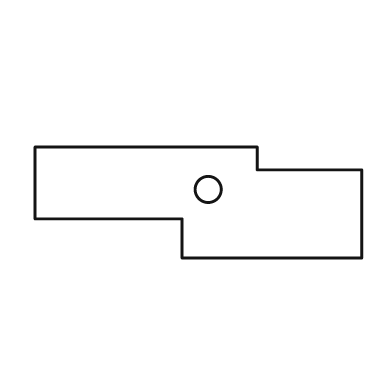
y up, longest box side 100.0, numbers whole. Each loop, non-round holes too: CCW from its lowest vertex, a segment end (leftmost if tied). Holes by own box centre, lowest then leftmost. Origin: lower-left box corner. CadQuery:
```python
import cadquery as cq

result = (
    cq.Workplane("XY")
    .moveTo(45.0, 0.0)
    .lineTo(100.0, 0.0)
    .lineTo(100.0, 27.0)
    .lineTo(68.0, 27.0)
    .lineTo(68.0, 34.0)
    .lineTo(0.0, 34.0)
    .lineTo(0.0, 12.0)
    .lineTo(45.0, 12.0)
    .close()
    .moveTo(53.0, 21.0)
    .circle(4.0)
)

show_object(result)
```